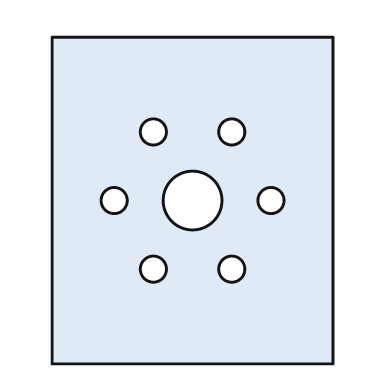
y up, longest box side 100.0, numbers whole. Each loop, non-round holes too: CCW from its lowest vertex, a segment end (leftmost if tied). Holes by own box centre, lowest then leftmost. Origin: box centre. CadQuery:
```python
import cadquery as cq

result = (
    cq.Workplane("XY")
    .moveTo(-43.0, -50.0)
    .lineTo(43.0, -50.0)
    .lineTo(43.0, 50.0)
    .lineTo(-43.0, 50.0)
    .close()
    .moveTo(-12.0, -21.0)
    .circle(4.0)
    .moveTo(12.0, -21.0)
    .circle(4.0)
    .moveTo(-24.0, 0.0)
    .circle(4.0)
    .moveTo(0.0, 0.0)
    .circle(9.0)
    .moveTo(24.0, 0.0)
    .circle(4.0)
    .moveTo(-12.0, 21.0)
    .circle(4.0)
    .moveTo(12.0, 21.0)
    .circle(4.0)
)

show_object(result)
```